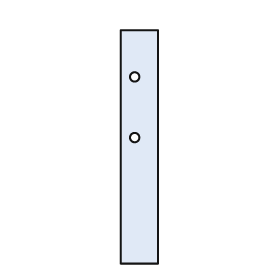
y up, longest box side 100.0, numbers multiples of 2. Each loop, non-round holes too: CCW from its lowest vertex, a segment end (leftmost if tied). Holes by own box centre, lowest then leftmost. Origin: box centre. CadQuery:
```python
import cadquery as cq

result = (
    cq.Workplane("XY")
    .moveTo(-8.0, -50.0)
    .lineTo(8.0, -50.0)
    .lineTo(8.0, 50.0)
    .lineTo(-8.0, 50.0)
    .close()
    .moveTo(-2.0, 4.0)
    .circle(2.0)
    .moveTo(-2.0, 30.0)
    .circle(2.0)
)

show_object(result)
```